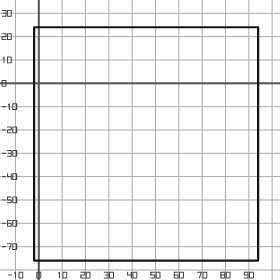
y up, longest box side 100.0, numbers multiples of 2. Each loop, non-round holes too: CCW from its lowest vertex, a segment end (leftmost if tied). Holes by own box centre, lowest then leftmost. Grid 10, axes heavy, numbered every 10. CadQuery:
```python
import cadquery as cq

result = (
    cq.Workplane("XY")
    .moveTo(-2.0, -76.0)
    .lineTo(94.0, -76.0)
    .lineTo(94.0, 24.0)
    .lineTo(-2.0, 24.0)
    .close()
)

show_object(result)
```